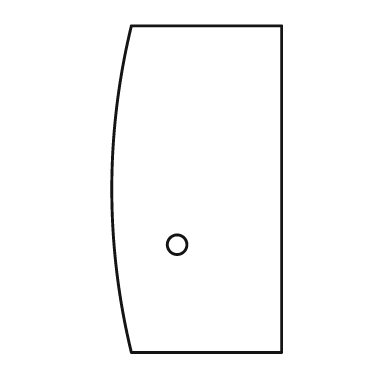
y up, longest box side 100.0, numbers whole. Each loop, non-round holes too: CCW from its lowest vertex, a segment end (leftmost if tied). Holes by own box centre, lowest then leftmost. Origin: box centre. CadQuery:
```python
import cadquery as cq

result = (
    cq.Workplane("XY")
    .moveTo(-20.0, -50.0)
    .lineTo(26.0, -50.0)
    .lineTo(26.0, 50.0)
    .lineTo(-20.0, 50.0)
    .threePointArc((-26.0, 0.0), (-20.0, -50.0))
    .close()
    .moveTo(-6.0, -17.0)
    .circle(3.0)
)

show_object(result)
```